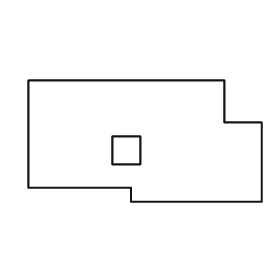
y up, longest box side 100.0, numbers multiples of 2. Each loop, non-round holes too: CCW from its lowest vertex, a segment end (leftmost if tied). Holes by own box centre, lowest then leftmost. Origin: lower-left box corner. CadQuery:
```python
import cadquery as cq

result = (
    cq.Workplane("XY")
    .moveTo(44.0, 0.0)
    .lineTo(100.0, 0.0)
    .lineTo(100.0, 34.0)
    .lineTo(84.0, 34.0)
    .lineTo(84.0, 52.0)
    .lineTo(0.0, 52.0)
    .lineTo(0.0, 6.0)
    .lineTo(44.0, 6.0)
    .close()
    .moveTo(36.0, 16.0)
    .lineTo(48.0, 16.0)
    .lineTo(48.0, 28.0)
    .lineTo(36.0, 28.0)
    .close()
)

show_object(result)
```